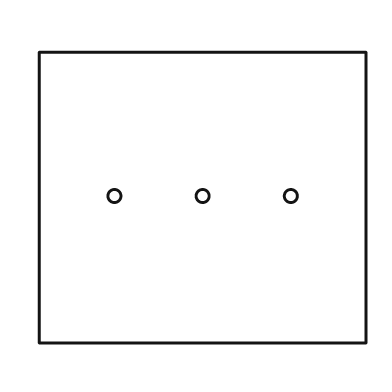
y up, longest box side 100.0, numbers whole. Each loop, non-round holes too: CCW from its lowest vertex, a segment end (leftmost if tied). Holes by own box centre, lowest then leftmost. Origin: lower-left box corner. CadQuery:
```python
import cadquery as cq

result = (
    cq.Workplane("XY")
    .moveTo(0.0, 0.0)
    .lineTo(100.0, 0.0)
    .lineTo(100.0, 89.0)
    .lineTo(0.0, 89.0)
    .close()
    .moveTo(23.0, 45.0)
    .circle(2.0)
    .moveTo(50.0, 45.0)
    .circle(2.0)
    .moveTo(77.0, 45.0)
    .circle(2.0)
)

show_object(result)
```